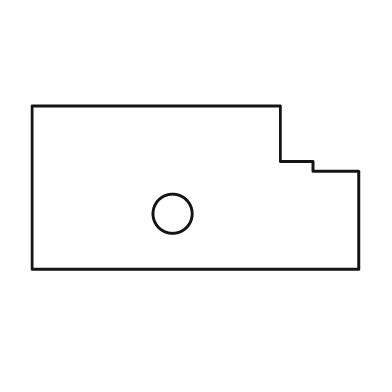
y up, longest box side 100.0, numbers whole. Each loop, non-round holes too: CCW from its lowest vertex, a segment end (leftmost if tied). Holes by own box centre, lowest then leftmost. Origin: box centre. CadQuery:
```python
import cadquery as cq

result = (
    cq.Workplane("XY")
    .moveTo(-50.0, -25.0)
    .lineTo(50.0, -25.0)
    .lineTo(50.0, 5.0)
    .lineTo(36.0, 5.0)
    .lineTo(36.0, 8.0)
    .lineTo(26.0, 8.0)
    .lineTo(26.0, 25.0)
    .lineTo(-50.0, 25.0)
    .close()
    .moveTo(-7.0, -8.0)
    .circle(6.0)
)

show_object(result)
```